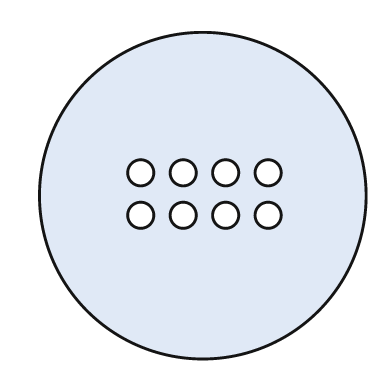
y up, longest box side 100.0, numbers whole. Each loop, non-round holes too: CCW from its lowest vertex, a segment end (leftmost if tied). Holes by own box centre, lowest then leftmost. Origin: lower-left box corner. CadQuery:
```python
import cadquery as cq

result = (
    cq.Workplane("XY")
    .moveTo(50.0, 50.0)
    .circle(50.0)
    .moveTo(31.0, 44.0)
    .circle(4.0)
    .moveTo(44.0, 44.0)
    .circle(4.0)
    .moveTo(57.0, 44.0)
    .circle(4.0)
    .moveTo(70.0, 44.0)
    .circle(4.0)
    .moveTo(31.0, 57.0)
    .circle(4.0)
    .moveTo(44.0, 57.0)
    .circle(4.0)
    .moveTo(57.0, 57.0)
    .circle(4.0)
    .moveTo(70.0, 57.0)
    .circle(4.0)
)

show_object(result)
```